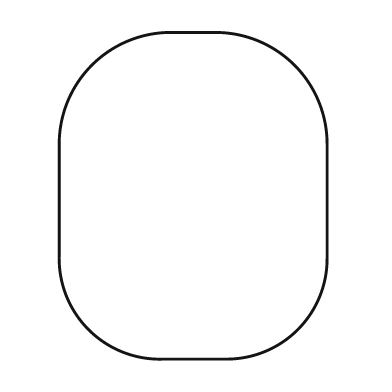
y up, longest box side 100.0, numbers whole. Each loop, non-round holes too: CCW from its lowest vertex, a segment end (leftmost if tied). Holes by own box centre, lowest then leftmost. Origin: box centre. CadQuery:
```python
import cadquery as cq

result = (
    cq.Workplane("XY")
    .moveTo(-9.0, -50.0)
    .lineTo(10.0, -50.0)
    .threePointArc((32.0, -41.0), (41.0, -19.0))
    .lineTo(41.0, 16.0)
    .threePointArc((31.0, 40.0), (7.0, 50.0))
    .lineTo(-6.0, 50.0)
    .threePointArc((-31.0, 40.0), (-41.0, 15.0))
    .lineTo(-41.0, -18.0)
    .threePointArc((-32.0, -41.0), (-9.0, -50.0))
    .close()
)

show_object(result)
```